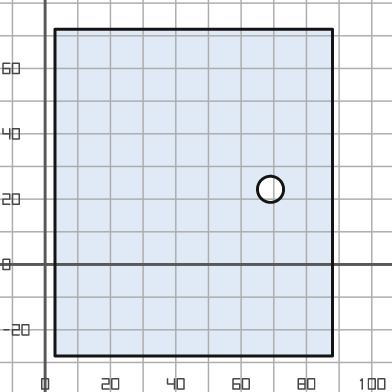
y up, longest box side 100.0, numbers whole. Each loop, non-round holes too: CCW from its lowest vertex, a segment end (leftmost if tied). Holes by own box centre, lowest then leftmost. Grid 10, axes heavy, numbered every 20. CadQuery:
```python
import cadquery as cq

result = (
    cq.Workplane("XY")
    .moveTo(3.0, -28.0)
    .lineTo(88.0, -28.0)
    .lineTo(88.0, 72.0)
    .lineTo(3.0, 72.0)
    .close()
    .moveTo(69.0, 23.0)
    .circle(4.0)
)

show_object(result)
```